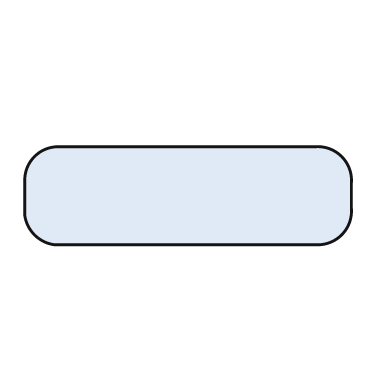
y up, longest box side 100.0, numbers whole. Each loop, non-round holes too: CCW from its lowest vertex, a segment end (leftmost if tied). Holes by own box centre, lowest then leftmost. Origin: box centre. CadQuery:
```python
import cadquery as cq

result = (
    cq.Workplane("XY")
    .moveTo(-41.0, -15.0)
    .lineTo(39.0, -15.0)
    .threePointArc((47.0, -12.0), (50.0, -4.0))
    .lineTo(50.0, 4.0)
    .threePointArc((47.0, 12.0), (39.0, 15.0))
    .lineTo(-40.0, 15.0)
    .threePointArc((-47.0, 12.0), (-50.0, 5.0))
    .lineTo(-50.0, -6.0)
    .threePointArc((-47.0, -12.0), (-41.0, -15.0))
    .close()
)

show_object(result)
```